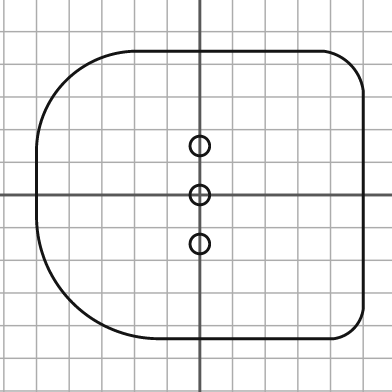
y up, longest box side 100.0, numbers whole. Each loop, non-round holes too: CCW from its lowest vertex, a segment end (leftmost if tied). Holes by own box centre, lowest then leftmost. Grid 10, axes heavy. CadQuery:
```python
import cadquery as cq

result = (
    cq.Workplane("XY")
    .moveTo(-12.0, -44.0)
    .lineTo(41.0, -44.0)
    .threePointArc((47.0, -41.0), (50.0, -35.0))
    .lineTo(50.0, 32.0)
    .threePointArc((46.0, 40.0), (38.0, 44.0))
    .lineTo(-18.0, 44.0)
    .threePointArc((-41.0, 35.0), (-50.0, 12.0))
    .lineTo(-50.0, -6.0)
    .threePointArc((-39.0, -33.0), (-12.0, -44.0))
    .close()
    .moveTo(0.0, -15.0)
    .circle(3.0)
    .moveTo(0.0, 0.0)
    .circle(3.0)
    .moveTo(0.0, 15.0)
    .circle(3.0)
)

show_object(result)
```